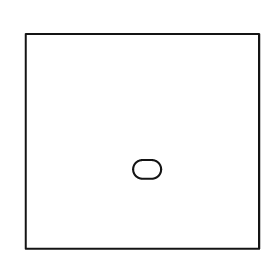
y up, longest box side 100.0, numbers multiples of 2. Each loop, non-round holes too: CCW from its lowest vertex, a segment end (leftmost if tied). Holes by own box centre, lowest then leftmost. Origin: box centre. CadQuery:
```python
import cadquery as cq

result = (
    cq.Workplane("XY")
    .moveTo(-50.0, -46.0)
    .lineTo(50.0, -46.0)
    .lineTo(50.0, 46.0)
    .lineTo(-50.0, 46.0)
    .close()
    .moveTo(0.0, -16.0)
    .lineTo(4.0, -16.0)
    .threePointArc((8.0, -12.0), (4.0, -8.0))
    .lineTo(0.0, -8.0)
    .threePointArc((-4.0, -12.0), (0.0, -16.0))
    .close()
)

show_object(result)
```